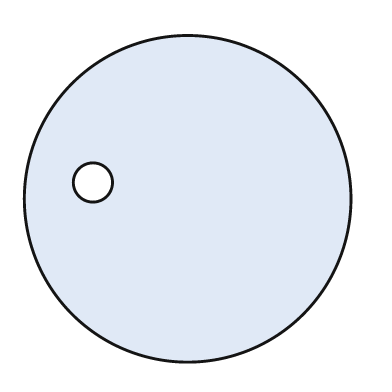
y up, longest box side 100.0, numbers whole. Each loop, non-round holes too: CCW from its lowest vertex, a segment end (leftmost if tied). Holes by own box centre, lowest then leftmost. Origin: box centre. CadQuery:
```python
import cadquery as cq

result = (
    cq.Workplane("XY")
    .moveTo(0.0, 0.0)
    .circle(50.0)
    .moveTo(-29.0, 5.0)
    .circle(6.0)
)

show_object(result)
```